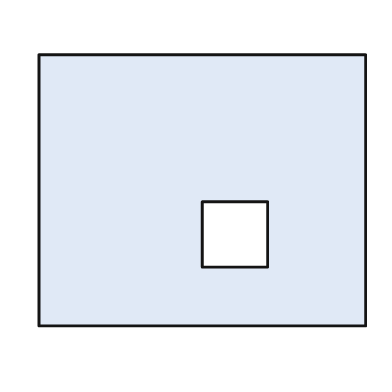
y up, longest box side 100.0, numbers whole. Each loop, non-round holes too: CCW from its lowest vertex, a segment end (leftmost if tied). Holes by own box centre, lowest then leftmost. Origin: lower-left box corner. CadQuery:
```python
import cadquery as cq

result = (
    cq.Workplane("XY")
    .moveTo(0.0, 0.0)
    .lineTo(100.0, 0.0)
    .lineTo(100.0, 83.0)
    .lineTo(0.0, 83.0)
    .close()
    .moveTo(50.0, 18.0)
    .lineTo(70.0, 18.0)
    .lineTo(70.0, 38.0)
    .lineTo(50.0, 38.0)
    .close()
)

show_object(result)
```